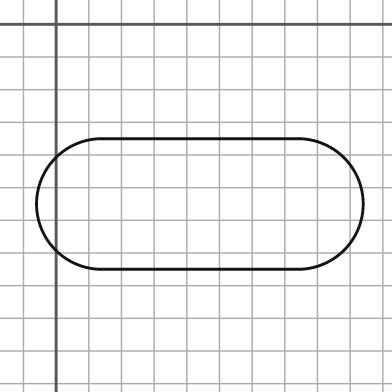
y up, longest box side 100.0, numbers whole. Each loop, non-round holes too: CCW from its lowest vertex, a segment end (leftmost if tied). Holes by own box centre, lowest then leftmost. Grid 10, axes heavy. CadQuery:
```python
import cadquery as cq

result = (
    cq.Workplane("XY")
    .moveTo(14.0, -75.0)
    .lineTo(74.0, -75.0)
    .threePointArc((94.0, -55.0), (74.0, -35.0))
    .lineTo(14.0, -35.0)
    .threePointArc((-6.0, -55.0), (14.0, -75.0))
    .close()
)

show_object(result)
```